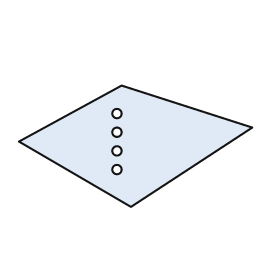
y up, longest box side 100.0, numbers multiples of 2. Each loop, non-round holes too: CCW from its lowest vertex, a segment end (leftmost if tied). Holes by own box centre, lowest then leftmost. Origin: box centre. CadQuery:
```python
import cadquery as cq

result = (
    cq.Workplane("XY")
    .moveTo(-2.0, -26.0)
    .lineTo(50.0, 8.0)
    .lineTo(-6.0, 26.0)
    .lineTo(-50.0, 2.0)
    .close()
    .moveTo(-8.0, -10.0)
    .circle(2.0)
    .moveTo(-8.0, -2.0)
    .circle(2.0)
    .moveTo(-8.0, 6.0)
    .circle(2.0)
    .moveTo(-8.0, 14.0)
    .circle(2.0)
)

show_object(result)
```